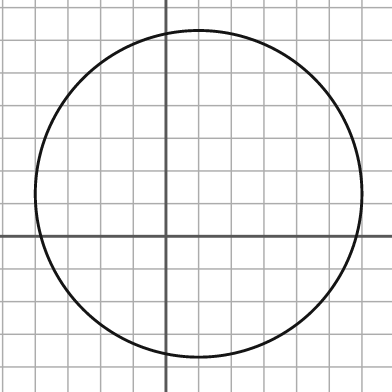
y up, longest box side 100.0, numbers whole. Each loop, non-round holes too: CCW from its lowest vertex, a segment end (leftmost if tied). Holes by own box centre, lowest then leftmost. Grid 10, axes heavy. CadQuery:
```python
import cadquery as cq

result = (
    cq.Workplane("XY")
    .moveTo(10.0, 13.0)
    .circle(50.0)
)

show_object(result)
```